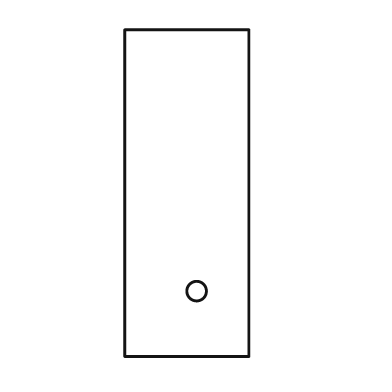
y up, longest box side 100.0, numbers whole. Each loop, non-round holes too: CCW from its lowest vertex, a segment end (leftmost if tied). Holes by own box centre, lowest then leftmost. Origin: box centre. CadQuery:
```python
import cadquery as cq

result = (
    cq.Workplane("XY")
    .moveTo(-19.0, -50.0)
    .lineTo(19.0, -50.0)
    .lineTo(19.0, 50.0)
    .lineTo(-19.0, 50.0)
    .close()
    .moveTo(3.0, -30.0)
    .circle(3.0)
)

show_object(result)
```